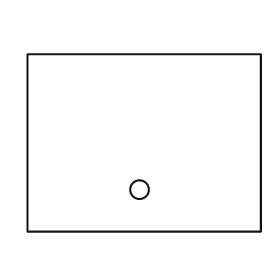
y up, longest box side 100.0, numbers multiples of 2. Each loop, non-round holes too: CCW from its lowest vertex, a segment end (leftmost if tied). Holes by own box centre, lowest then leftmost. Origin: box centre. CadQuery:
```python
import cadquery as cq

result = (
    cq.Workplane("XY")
    .moveTo(-50.0, -38.0)
    .lineTo(50.0, -38.0)
    .lineTo(50.0, 38.0)
    .lineTo(-50.0, 38.0)
    .close()
    .moveTo(-2.0, -20.0)
    .circle(4.0)
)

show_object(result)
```